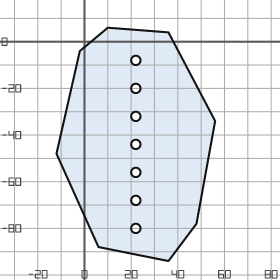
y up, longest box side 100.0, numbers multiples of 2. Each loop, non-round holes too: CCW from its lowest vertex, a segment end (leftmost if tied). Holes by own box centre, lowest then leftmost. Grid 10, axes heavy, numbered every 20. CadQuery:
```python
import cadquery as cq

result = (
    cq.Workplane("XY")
    .moveTo(36.0, -94.0)
    .lineTo(48.0, -78.0)
    .lineTo(56.0, -34.0)
    .lineTo(36.0, 4.0)
    .lineTo(10.0, 6.0)
    .lineTo(-2.0, -4.0)
    .lineTo(-12.0, -48.0)
    .lineTo(6.0, -88.0)
    .close()
    .moveTo(22.0, -80.0)
    .circle(2.0)
    .moveTo(22.0, -68.0)
    .circle(2.0)
    .moveTo(22.0, -56.0)
    .circle(2.0)
    .moveTo(22.0, -44.0)
    .circle(2.0)
    .moveTo(22.0, -32.0)
    .circle(2.0)
    .moveTo(22.0, -20.0)
    .circle(2.0)
    .moveTo(22.0, -8.0)
    .circle(2.0)
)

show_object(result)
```